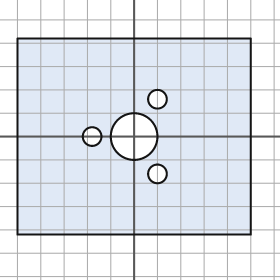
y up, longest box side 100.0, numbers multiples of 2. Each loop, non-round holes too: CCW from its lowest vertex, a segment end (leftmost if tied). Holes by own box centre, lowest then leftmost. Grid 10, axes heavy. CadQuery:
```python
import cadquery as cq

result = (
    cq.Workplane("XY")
    .moveTo(-50.0, -42.0)
    .lineTo(50.0, -42.0)
    .lineTo(50.0, 42.0)
    .lineTo(-50.0, 42.0)
    .close()
    .moveTo(10.0, -16.0)
    .circle(4.0)
    .moveTo(-18.0, 0.0)
    .circle(4.0)
    .moveTo(0.0, 0.0)
    .circle(10.0)
    .moveTo(10.0, 16.0)
    .circle(4.0)
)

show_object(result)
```